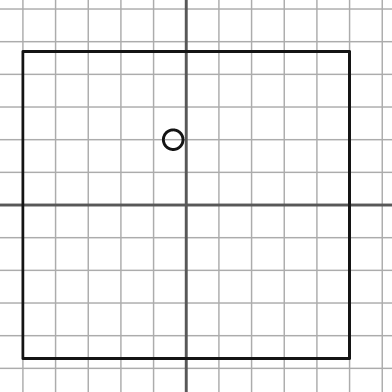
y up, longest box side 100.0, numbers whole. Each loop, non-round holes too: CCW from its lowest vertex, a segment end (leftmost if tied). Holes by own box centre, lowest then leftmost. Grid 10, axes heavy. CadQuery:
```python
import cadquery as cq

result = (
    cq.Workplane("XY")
    .moveTo(-50.0, -47.0)
    .lineTo(50.0, -47.0)
    .lineTo(50.0, 47.0)
    .lineTo(-50.0, 47.0)
    .close()
    .moveTo(-4.0, 20.0)
    .circle(3.0)
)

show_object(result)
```